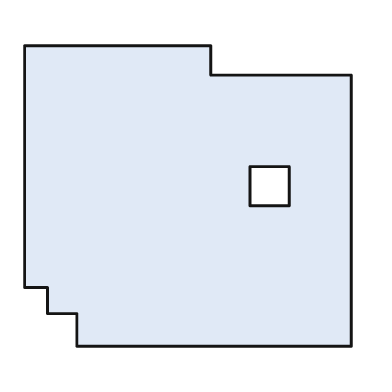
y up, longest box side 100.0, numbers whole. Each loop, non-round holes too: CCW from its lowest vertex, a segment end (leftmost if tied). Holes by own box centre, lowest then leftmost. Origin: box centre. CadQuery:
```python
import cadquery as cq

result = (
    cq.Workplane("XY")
    .moveTo(-34.0, -46.0)
    .lineTo(50.0, -46.0)
    .lineTo(50.0, 37.0)
    .lineTo(7.0, 37.0)
    .lineTo(7.0, 46.0)
    .lineTo(-50.0, 46.0)
    .lineTo(-50.0, -28.0)
    .lineTo(-43.0, -28.0)
    .lineTo(-43.0, -36.0)
    .lineTo(-34.0, -36.0)
    .close()
    .moveTo(19.0, -3.0)
    .lineTo(31.0, -3.0)
    .lineTo(31.0, 9.0)
    .lineTo(19.0, 9.0)
    .close()
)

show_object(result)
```